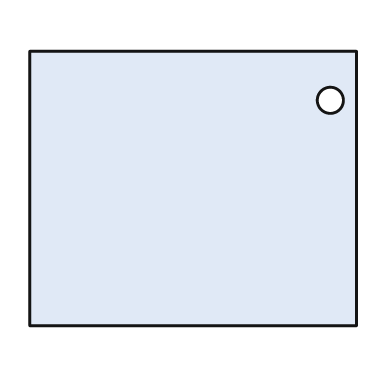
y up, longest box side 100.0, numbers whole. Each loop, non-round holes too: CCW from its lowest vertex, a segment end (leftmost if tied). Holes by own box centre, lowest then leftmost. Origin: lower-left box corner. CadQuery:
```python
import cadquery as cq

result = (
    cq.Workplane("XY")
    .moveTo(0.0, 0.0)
    .lineTo(100.0, 0.0)
    .lineTo(100.0, 84.0)
    .lineTo(0.0, 84.0)
    .close()
    .moveTo(92.0, 69.0)
    .circle(4.0)
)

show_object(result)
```